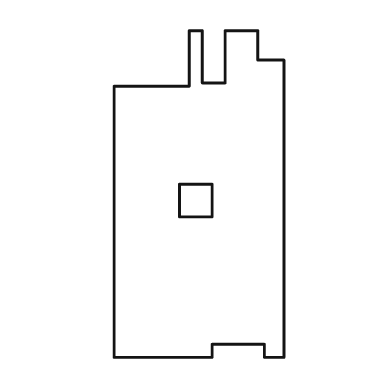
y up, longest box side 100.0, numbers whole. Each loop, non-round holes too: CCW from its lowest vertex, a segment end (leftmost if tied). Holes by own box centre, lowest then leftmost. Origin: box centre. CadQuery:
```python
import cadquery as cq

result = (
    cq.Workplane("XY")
    .moveTo(-26.0, -50.0)
    .lineTo(4.0, -50.0)
    .lineTo(4.0, -46.0)
    .lineTo(20.0, -46.0)
    .lineTo(20.0, -50.0)
    .lineTo(26.0, -50.0)
    .lineTo(26.0, 41.0)
    .lineTo(18.0, 41.0)
    .lineTo(18.0, 50.0)
    .lineTo(8.0, 50.0)
    .lineTo(8.0, 34.0)
    .lineTo(1.0, 34.0)
    .lineTo(1.0, 50.0)
    .lineTo(-3.0, 50.0)
    .lineTo(-3.0, 33.0)
    .lineTo(-26.0, 33.0)
    .close()
    .moveTo(-6.0, -7.0)
    .lineTo(4.0, -7.0)
    .lineTo(4.0, 3.0)
    .lineTo(-6.0, 3.0)
    .close()
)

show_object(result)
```